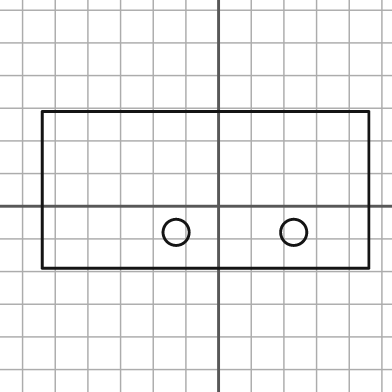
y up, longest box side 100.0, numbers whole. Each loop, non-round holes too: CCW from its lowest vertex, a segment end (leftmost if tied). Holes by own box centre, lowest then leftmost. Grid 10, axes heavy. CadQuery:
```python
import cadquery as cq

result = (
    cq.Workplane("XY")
    .moveTo(-54.0, -19.0)
    .lineTo(46.0, -19.0)
    .lineTo(46.0, 29.0)
    .lineTo(-54.0, 29.0)
    .close()
    .moveTo(-13.0, -8.0)
    .circle(4.0)
    .moveTo(23.0, -8.0)
    .circle(4.0)
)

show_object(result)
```